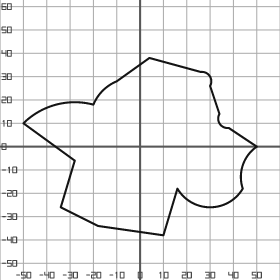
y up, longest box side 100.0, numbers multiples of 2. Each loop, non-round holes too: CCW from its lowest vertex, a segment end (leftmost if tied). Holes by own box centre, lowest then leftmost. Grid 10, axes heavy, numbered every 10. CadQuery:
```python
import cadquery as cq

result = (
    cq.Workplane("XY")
    .moveTo(10.0, -38.0)
    .lineTo(16.0, -18.0)
    .threePointArc((30.0, -26.0), (44.0, -18.0))
    .threePointArc((44.0, -8.0), (50.0, 0.0))
    .lineTo(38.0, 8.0)
    .threePointArc((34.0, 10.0), (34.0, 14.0))
    .lineTo(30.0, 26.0)
    .threePointArc((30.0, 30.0), (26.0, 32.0))
    .lineTo(4.0, 38.0)
    .lineTo(-10.0, 28.0)
    .threePointArc((-16.0, 24.0), (-20.0, 18.0))
    .threePointArc((-36.0, 18.0), (-50.0, 10.0))
    .lineTo(-28.0, -6.0)
    .lineTo(-34.0, -26.0)
    .lineTo(-18.0, -34.0)
    .close()
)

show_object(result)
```